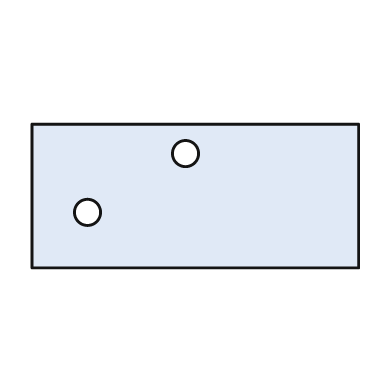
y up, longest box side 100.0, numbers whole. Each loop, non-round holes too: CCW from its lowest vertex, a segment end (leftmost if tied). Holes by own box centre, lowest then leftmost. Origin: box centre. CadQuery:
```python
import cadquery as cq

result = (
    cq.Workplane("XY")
    .moveTo(-50.0, -22.0)
    .lineTo(50.0, -22.0)
    .lineTo(50.0, 22.0)
    .lineTo(-50.0, 22.0)
    .close()
    .moveTo(-33.0, -5.0)
    .circle(4.0)
    .moveTo(-3.0, 13.0)
    .circle(4.0)
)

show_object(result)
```